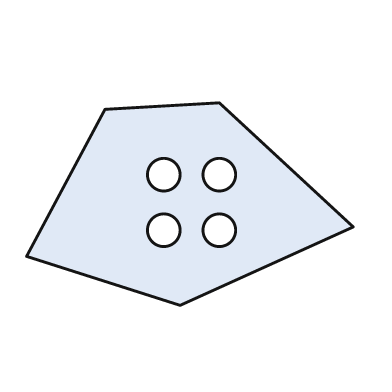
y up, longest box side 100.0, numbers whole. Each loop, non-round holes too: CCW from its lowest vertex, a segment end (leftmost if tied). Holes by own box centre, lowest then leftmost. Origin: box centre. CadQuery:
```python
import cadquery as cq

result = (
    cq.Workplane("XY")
    .moveTo(-3.0, -31.0)
    .lineTo(50.0, -7.0)
    .lineTo(9.0, 31.0)
    .lineTo(-26.0, 29.0)
    .lineTo(-50.0, -16.0)
    .close()
    .moveTo(-8.0, -8.0)
    .circle(5.0)
    .moveTo(9.0, -8.0)
    .circle(5.0)
    .moveTo(-8.0, 9.0)
    .circle(5.0)
    .moveTo(9.0, 9.0)
    .circle(5.0)
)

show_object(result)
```